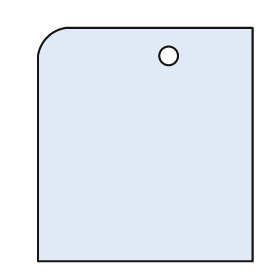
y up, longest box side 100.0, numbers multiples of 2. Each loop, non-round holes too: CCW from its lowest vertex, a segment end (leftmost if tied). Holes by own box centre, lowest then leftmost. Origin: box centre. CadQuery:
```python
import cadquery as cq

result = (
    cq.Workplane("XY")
    .moveTo(-46.0, -50.0)
    .lineTo(46.0, -50.0)
    .lineTo(46.0, 50.0)
    .lineTo(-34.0, 50.0)
    .threePointArc((-42.0, 46.0), (-46.0, 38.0))
    .close()
    .moveTo(10.0, 38.0)
    .circle(4.0)
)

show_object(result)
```